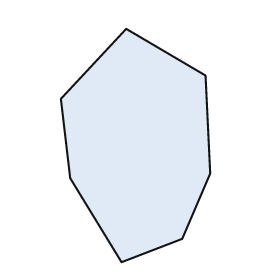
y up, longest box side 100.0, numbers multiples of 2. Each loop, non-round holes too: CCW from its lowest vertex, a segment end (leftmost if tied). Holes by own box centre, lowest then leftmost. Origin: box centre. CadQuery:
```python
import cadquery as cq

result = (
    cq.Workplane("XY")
    .moveTo(-6.0, -50.0)
    .lineTo(20.0, -40.0)
    .lineTo(32.0, -12.0)
    .lineTo(30.0, 30.0)
    .lineTo(-4.0, 50.0)
    .lineTo(-32.0, 20.0)
    .lineTo(-28.0, -14.0)
    .close()
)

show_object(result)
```